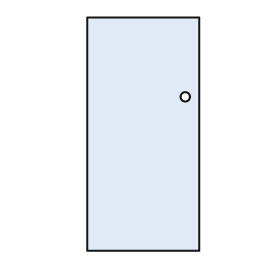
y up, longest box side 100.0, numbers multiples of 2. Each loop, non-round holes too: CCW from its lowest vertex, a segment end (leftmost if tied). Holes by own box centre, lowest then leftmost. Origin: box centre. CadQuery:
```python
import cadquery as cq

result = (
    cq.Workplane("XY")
    .moveTo(-24.0, -50.0)
    .lineTo(24.0, -50.0)
    .lineTo(24.0, 50.0)
    .lineTo(-24.0, 50.0)
    .close()
    .moveTo(18.0, 16.0)
    .circle(2.0)
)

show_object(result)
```